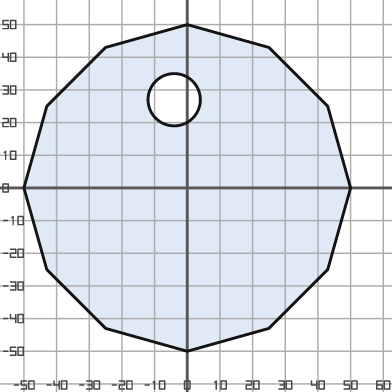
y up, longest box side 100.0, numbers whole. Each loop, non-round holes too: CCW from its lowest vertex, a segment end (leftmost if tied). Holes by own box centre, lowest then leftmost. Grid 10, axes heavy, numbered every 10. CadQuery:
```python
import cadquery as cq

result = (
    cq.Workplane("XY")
    .moveTo(0.0, -50.0)
    .lineTo(25.0, -43.0)
    .lineTo(43.0, -25.0)
    .lineTo(50.0, 0.0)
    .lineTo(43.0, 25.0)
    .lineTo(25.0, 43.0)
    .lineTo(0.0, 50.0)
    .lineTo(-25.0, 43.0)
    .lineTo(-43.0, 25.0)
    .lineTo(-50.0, 0.0)
    .lineTo(-43.0, -25.0)
    .lineTo(-25.0, -43.0)
    .close()
    .moveTo(-4.0, 27.0)
    .circle(8.0)
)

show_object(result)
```